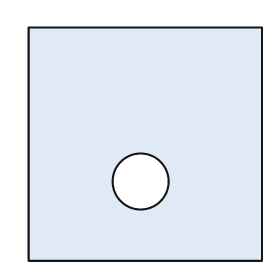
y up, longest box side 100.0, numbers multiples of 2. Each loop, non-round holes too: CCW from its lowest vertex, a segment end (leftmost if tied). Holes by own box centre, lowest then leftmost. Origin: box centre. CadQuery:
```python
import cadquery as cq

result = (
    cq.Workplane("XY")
    .moveTo(-50.0, -50.0)
    .lineTo(50.0, -50.0)
    .lineTo(50.0, 50.0)
    .lineTo(-50.0, 50.0)
    .close()
    .moveTo(-2.0, -16.0)
    .circle(12.0)
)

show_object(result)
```